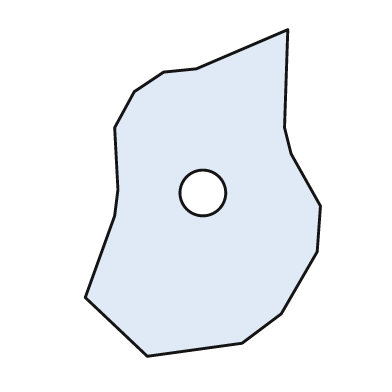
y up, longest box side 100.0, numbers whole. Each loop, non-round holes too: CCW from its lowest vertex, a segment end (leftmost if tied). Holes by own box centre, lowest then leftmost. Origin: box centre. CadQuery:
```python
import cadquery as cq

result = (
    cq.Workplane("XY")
    .moveTo(-17.0, -50.0)
    .lineTo(12.0, -46.0)
    .lineTo(24.0, -37.0)
    .lineTo(35.0, -18.0)
    .lineTo(36.0, -4.0)
    .lineTo(27.0, 12.0)
    .lineTo(25.0, 20.0)
    .lineTo(26.0, 50.0)
    .lineTo(-2.0, 38.0)
    .lineTo(-12.0, 37.0)
    .lineTo(-21.0, 31.0)
    .lineTo(-27.0, 20.0)
    .lineTo(-26.0, 1.0)
    .lineTo(-27.0, -7.0)
    .lineTo(-36.0, -32.0)
    .close()
    .moveTo(0.0, 0.0)
    .circle(7.0)
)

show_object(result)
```